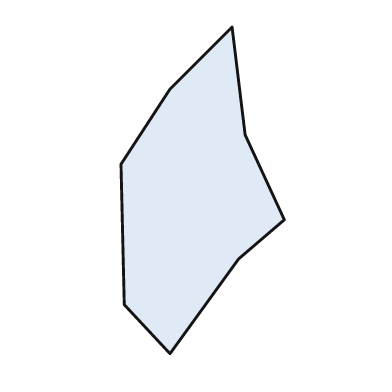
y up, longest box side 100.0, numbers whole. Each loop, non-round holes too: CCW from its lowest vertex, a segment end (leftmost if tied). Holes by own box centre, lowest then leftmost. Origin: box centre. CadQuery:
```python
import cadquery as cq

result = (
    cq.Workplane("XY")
    .moveTo(-10.0, -50.0)
    .lineTo(11.0, -21.0)
    .lineTo(25.0, -9.0)
    .lineTo(13.0, 17.0)
    .lineTo(9.0, 50.0)
    .lineTo(-10.0, 31.0)
    .lineTo(-25.0, 8.0)
    .lineTo(-24.0, -35.0)
    .close()
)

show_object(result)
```